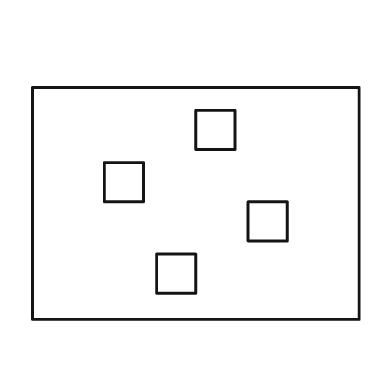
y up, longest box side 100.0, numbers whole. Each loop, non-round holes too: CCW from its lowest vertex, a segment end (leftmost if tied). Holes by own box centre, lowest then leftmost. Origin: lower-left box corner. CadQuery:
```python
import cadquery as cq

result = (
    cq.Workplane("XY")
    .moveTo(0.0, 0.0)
    .lineTo(100.0, 0.0)
    .lineTo(100.0, 71.0)
    .lineTo(0.0, 71.0)
    .close()
    .moveTo(38.0, 8.0)
    .lineTo(50.0, 8.0)
    .lineTo(50.0, 20.0)
    .lineTo(38.0, 20.0)
    .close()
    .moveTo(66.0, 24.0)
    .lineTo(78.0, 24.0)
    .lineTo(78.0, 36.0)
    .lineTo(66.0, 36.0)
    .close()
    .moveTo(22.0, 36.0)
    .lineTo(34.0, 36.0)
    .lineTo(34.0, 48.0)
    .lineTo(22.0, 48.0)
    .close()
    .moveTo(50.0, 52.0)
    .lineTo(62.0, 52.0)
    .lineTo(62.0, 64.0)
    .lineTo(50.0, 64.0)
    .close()
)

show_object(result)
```